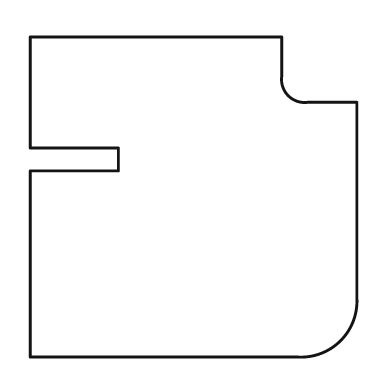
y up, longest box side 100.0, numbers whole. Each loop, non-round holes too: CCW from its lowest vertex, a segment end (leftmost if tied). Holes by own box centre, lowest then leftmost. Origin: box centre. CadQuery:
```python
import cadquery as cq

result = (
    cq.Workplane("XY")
    .moveTo(-50.0, -49.0)
    .lineTo(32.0, -49.0)
    .threePointArc((45.0, -44.0), (50.0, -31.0))
    .lineTo(50.0, 29.0)
    .lineTo(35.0, 29.0)
    .threePointArc((29.0, 31.0), (27.0, 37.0))
    .lineTo(27.0, 49.0)
    .lineTo(-50.0, 49.0)
    .lineTo(-50.0, 15.0)
    .lineTo(-23.0, 15.0)
    .lineTo(-23.0, 8.0)
    .lineTo(-50.0, 8.0)
    .close()
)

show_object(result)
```